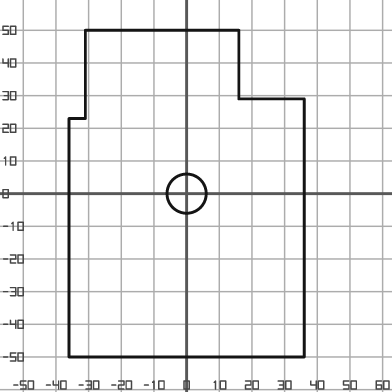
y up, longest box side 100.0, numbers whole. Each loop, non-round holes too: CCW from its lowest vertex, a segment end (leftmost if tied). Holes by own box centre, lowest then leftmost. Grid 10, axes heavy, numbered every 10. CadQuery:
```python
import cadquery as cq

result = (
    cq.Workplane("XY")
    .moveTo(-36.0, -50.0)
    .lineTo(36.0, -50.0)
    .lineTo(36.0, 29.0)
    .lineTo(16.0, 29.0)
    .lineTo(16.0, 50.0)
    .lineTo(-31.0, 50.0)
    .lineTo(-31.0, 23.0)
    .lineTo(-36.0, 23.0)
    .close()
    .moveTo(0.0, 0.0)
    .circle(6.0)
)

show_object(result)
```